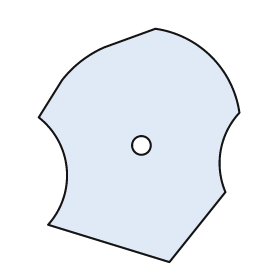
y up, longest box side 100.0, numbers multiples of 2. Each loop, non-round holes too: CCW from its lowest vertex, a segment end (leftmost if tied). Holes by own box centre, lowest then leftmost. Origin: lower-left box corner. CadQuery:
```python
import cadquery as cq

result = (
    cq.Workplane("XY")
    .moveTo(56.0, 0.0)
    .lineTo(80.0, 30.0)
    .threePointArc((78.0, 48.0), (86.0, 64.0))
    .threePointArc((74.0, 88.0), (50.0, 100.0))
    .lineTo(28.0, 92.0)
    .threePointArc((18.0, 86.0), (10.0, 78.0))
    .lineTo(0.0, 62.0)
    .threePointArc((12.0, 40.0), (4.0, 16.0))
    .close()
    .moveTo(44.0, 50.0)
    .circle(4.0)
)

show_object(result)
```